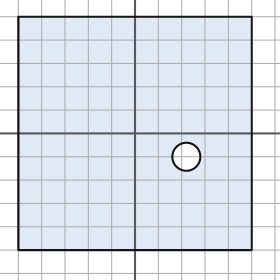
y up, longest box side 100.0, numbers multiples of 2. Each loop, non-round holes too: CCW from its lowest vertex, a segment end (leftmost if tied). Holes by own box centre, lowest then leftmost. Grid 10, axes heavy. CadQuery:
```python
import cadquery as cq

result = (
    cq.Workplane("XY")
    .moveTo(-50.0, -50.0)
    .lineTo(50.0, -50.0)
    .lineTo(50.0, 50.0)
    .lineTo(-50.0, 50.0)
    .close()
    .moveTo(22.0, -10.0)
    .circle(6.0)
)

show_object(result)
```